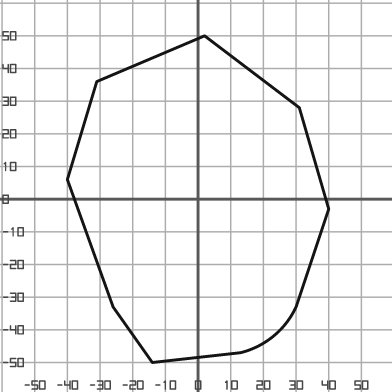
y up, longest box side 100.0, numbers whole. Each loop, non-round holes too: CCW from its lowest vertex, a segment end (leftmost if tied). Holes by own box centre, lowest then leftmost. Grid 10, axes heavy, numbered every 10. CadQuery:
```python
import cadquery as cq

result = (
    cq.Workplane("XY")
    .moveTo(-14.0, -50.0)
    .lineTo(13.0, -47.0)
    .threePointArc((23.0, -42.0), (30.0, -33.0))
    .lineTo(40.0, -3.0)
    .lineTo(31.0, 28.0)
    .lineTo(2.0, 50.0)
    .lineTo(-31.0, 36.0)
    .lineTo(-40.0, 6.0)
    .lineTo(-26.0, -33.0)
    .close()
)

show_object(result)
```